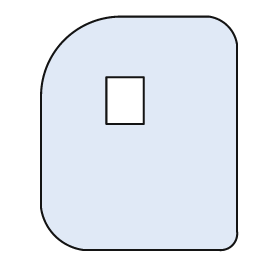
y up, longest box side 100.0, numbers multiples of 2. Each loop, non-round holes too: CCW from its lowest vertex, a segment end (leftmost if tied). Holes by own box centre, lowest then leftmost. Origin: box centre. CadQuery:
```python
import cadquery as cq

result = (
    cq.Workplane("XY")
    .moveTo(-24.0, -50.0)
    .lineTo(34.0, -50.0)
    .threePointArc((40.0, -48.0), (42.0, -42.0))
    .lineTo(42.0, 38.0)
    .threePointArc((38.0, 46.0), (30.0, 50.0))
    .lineTo(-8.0, 50.0)
    .threePointArc((-32.0, 40.0), (-42.0, 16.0))
    .lineTo(-42.0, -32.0)
    .threePointArc((-36.0, -44.0), (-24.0, -50.0))
    .close()
    .moveTo(-14.0, 4.0)
    .lineTo(2.0, 4.0)
    .lineTo(2.0, 24.0)
    .lineTo(-14.0, 24.0)
    .close()
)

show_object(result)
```